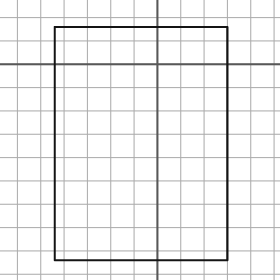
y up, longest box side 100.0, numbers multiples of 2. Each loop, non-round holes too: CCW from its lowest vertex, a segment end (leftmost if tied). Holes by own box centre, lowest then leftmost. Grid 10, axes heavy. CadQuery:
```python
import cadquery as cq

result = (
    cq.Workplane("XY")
    .moveTo(-44.0, -84.0)
    .lineTo(30.0, -84.0)
    .lineTo(30.0, 16.0)
    .lineTo(-44.0, 16.0)
    .close()
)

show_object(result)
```